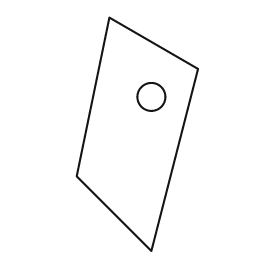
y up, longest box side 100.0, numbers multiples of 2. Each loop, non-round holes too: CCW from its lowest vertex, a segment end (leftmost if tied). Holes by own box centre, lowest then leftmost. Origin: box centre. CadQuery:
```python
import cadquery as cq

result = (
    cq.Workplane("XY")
    .moveTo(6.0, -50.0)
    .lineTo(26.0, 28.0)
    .lineTo(-12.0, 50.0)
    .lineTo(-26.0, -18.0)
    .close()
    .moveTo(6.0, 16.0)
    .circle(6.0)
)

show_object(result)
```